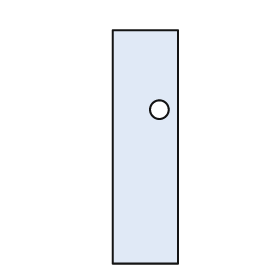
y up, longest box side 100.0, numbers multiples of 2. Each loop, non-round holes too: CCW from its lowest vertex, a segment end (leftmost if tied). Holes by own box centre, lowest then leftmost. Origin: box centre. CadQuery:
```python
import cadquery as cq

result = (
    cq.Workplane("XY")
    .moveTo(-14.0, -50.0)
    .lineTo(14.0, -50.0)
    .lineTo(14.0, 50.0)
    .lineTo(-14.0, 50.0)
    .close()
    .moveTo(6.0, 16.0)
    .circle(4.0)
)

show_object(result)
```